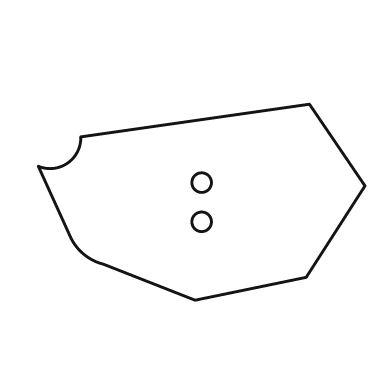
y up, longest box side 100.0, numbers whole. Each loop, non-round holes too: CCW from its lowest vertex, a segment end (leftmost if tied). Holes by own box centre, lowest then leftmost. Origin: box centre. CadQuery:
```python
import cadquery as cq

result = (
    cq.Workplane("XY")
    .moveTo(-2.0, -30.0)
    .lineTo(32.0, -23.0)
    .lineTo(50.0, 5.0)
    .lineTo(33.0, 30.0)
    .lineTo(-37.0, 20.0)
    .threePointArc((-41.0, 12.0), (-50.0, 11.0))
    .lineTo(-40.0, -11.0)
    .threePointArc((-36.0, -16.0), (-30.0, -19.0))
    .close()
    .moveTo(0.0, -6.0)
    .circle(3.0)
    .moveTo(0.0, 6.0)
    .circle(3.0)
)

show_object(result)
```